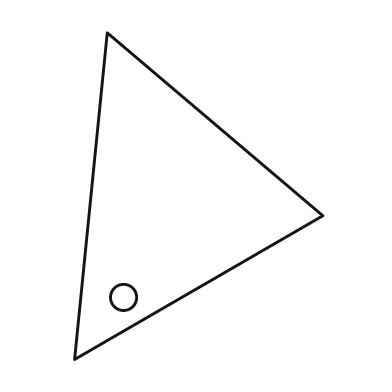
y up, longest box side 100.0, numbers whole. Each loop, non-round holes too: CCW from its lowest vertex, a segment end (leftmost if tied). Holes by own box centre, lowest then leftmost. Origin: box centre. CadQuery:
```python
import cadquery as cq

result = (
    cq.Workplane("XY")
    .moveTo(-38.0, -50.0)
    .lineTo(38.0, -6.0)
    .lineTo(-28.0, 50.0)
    .close()
    .moveTo(-23.0, -31.0)
    .circle(4.0)
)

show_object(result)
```